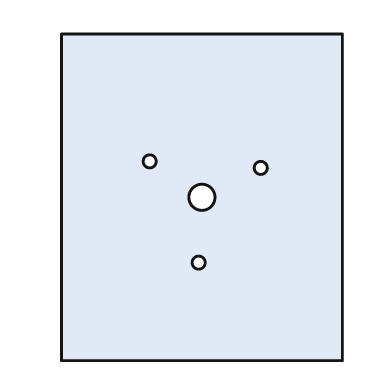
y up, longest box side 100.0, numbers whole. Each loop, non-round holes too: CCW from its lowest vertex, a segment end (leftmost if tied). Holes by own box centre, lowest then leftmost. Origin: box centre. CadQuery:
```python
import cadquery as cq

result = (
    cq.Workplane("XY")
    .moveTo(-43.0, -50.0)
    .lineTo(43.0, -50.0)
    .lineTo(43.0, 50.0)
    .lineTo(-43.0, 50.0)
    .close()
    .moveTo(-1.0, -20.0)
    .circle(2.0)
    .moveTo(0.0, 0.0)
    .circle(4.0)
    .moveTo(18.0, 9.0)
    .circle(2.0)
    .moveTo(-16.0, 11.0)
    .circle(2.0)
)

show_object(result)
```